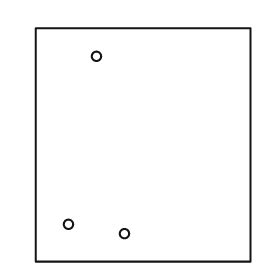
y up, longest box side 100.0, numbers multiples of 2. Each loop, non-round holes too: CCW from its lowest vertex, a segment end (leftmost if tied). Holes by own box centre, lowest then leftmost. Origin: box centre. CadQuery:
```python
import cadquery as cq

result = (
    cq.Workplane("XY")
    .moveTo(-46.0, -50.0)
    .lineTo(46.0, -50.0)
    .lineTo(46.0, 50.0)
    .lineTo(-46.0, 50.0)
    .close()
    .moveTo(-8.0, -38.0)
    .circle(2.0)
    .moveTo(-32.0, -34.0)
    .circle(2.0)
    .moveTo(-20.0, 38.0)
    .circle(2.0)
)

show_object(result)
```